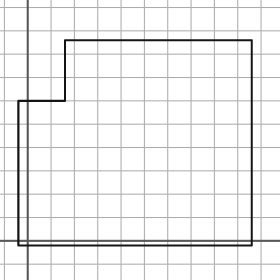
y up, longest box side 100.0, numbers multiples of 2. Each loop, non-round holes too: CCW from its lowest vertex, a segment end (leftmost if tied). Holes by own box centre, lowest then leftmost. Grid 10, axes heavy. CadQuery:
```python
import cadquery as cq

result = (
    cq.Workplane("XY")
    .moveTo(-4.0, -2.0)
    .lineTo(96.0, -2.0)
    .lineTo(96.0, 86.0)
    .lineTo(16.0, 86.0)
    .lineTo(16.0, 60.0)
    .lineTo(-4.0, 60.0)
    .close()
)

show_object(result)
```